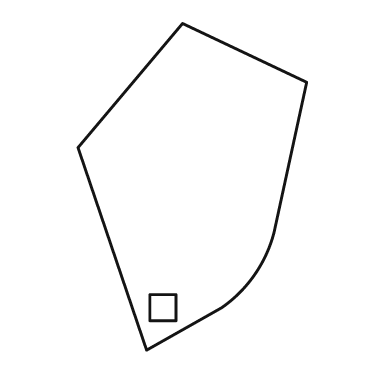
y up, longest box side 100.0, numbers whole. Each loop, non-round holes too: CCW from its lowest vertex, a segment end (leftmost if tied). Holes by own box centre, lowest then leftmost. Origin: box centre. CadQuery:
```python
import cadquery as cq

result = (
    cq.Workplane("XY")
    .moveTo(-14.0, -50.0)
    .lineTo(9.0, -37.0)
    .threePointArc((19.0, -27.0), (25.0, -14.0))
    .lineTo(35.0, 32.0)
    .lineTo(-3.0, 50.0)
    .lineTo(-35.0, 12.0)
    .close()
    .moveTo(-13.0, -41.0)
    .lineTo(-5.0, -41.0)
    .lineTo(-5.0, -33.0)
    .lineTo(-13.0, -33.0)
    .close()
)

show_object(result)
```